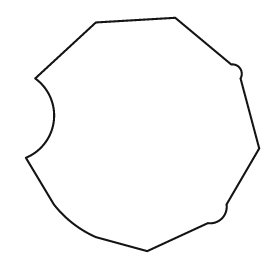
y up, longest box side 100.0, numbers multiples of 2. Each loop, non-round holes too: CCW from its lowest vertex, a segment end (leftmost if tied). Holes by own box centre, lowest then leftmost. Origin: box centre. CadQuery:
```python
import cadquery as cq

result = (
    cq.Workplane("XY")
    .moveTo(2.0, -50.0)
    .lineTo(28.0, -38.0)
    .threePointArc((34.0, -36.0), (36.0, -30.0))
    .lineTo(50.0, -6.0)
    .lineTo(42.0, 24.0)
    .threePointArc((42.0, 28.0), (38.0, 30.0))
    .lineTo(14.0, 50.0)
    .lineTo(-20.0, 48.0)
    .lineTo(-46.0, 24.0)
    .threePointArc((-38.0, 6.0), (-50.0, -10.0))
    .lineTo(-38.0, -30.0)
    .threePointArc((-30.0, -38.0), (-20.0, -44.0))
    .close()
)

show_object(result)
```